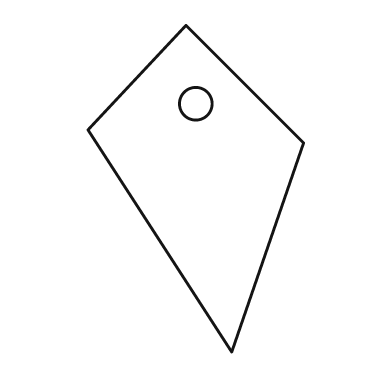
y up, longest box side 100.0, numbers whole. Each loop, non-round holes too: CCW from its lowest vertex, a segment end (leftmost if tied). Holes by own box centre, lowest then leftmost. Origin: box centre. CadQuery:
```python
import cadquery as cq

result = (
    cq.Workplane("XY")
    .moveTo(11.0, -50.0)
    .lineTo(33.0, 14.0)
    .lineTo(-3.0, 50.0)
    .lineTo(-33.0, 18.0)
    .close()
    .moveTo(0.0, 26.0)
    .circle(5.0)
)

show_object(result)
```